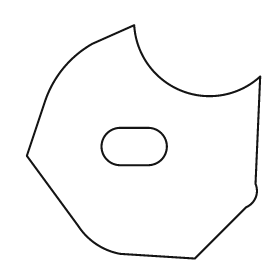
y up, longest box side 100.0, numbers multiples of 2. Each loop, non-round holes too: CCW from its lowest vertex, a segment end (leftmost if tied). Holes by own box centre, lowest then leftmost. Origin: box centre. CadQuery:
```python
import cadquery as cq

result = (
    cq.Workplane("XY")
    .moveTo(22.0, -50.0)
    .lineTo(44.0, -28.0)
    .threePointArc((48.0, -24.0), (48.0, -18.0))
    .lineTo(50.0, 28.0)
    .threePointArc((16.0, 22.0), (-4.0, 50.0))
    .lineTo(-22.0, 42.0)
    .threePointArc((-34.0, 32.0), (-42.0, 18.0))
    .lineTo(-50.0, -6.0)
    .lineTo(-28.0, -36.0)
    .threePointArc((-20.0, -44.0), (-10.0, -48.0))
    .close()
    .moveTo(-10.0, -10.0)
    .lineTo(2.0, -10.0)
    .threePointArc((10.0, -2.0), (2.0, 6.0))
    .lineTo(-10.0, 6.0)
    .threePointArc((-18.0, -2.0), (-10.0, -10.0))
    .close()
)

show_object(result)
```